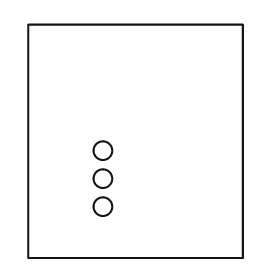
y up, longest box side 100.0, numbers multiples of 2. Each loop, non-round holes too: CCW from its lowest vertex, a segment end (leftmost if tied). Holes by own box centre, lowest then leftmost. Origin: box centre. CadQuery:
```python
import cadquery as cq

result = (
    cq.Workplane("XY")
    .moveTo(-46.0, -50.0)
    .lineTo(46.0, -50.0)
    .lineTo(46.0, 50.0)
    .lineTo(-46.0, 50.0)
    .close()
    .moveTo(-14.0, -28.0)
    .circle(4.0)
    .moveTo(-14.0, -16.0)
    .circle(4.0)
    .moveTo(-14.0, -4.0)
    .circle(4.0)
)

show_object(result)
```